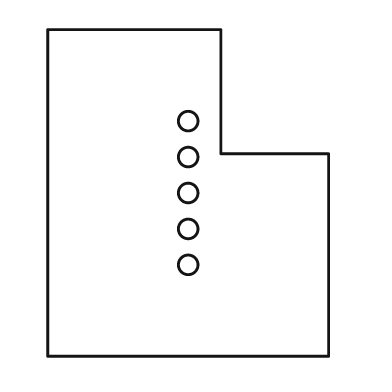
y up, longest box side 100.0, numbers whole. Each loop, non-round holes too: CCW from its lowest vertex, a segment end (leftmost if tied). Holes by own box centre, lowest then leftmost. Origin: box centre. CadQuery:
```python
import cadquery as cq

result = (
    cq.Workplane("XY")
    .moveTo(-43.0, -50.0)
    .lineTo(43.0, -50.0)
    .lineTo(43.0, 12.0)
    .lineTo(10.0, 12.0)
    .lineTo(10.0, 50.0)
    .lineTo(-43.0, 50.0)
    .close()
    .moveTo(0.0, -22.0)
    .circle(3.0)
    .moveTo(0.0, -11.0)
    .circle(3.0)
    .moveTo(0.0, 0.0)
    .circle(3.0)
    .moveTo(0.0, 11.0)
    .circle(3.0)
    .moveTo(0.0, 22.0)
    .circle(3.0)
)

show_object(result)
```